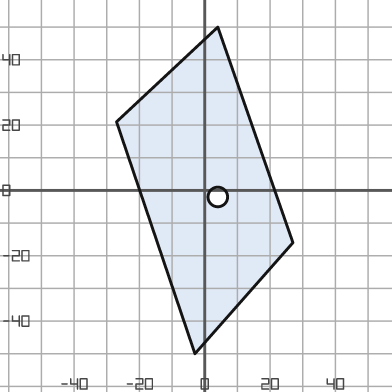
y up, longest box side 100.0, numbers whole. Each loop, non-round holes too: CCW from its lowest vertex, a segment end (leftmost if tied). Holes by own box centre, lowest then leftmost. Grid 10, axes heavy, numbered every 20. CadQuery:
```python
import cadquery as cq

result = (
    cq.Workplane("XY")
    .moveTo(-3.0, -50.0)
    .lineTo(27.0, -16.0)
    .lineTo(4.0, 50.0)
    .lineTo(-27.0, 21.0)
    .close()
    .moveTo(4.0, -2.0)
    .circle(3.0)
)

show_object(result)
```